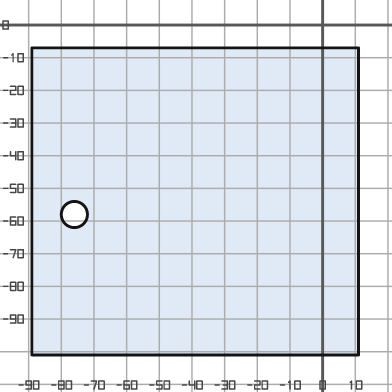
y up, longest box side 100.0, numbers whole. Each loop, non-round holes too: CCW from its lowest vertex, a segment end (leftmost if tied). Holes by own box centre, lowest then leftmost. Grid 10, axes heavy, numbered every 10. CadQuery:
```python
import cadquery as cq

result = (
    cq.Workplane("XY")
    .moveTo(-89.0, -101.0)
    .lineTo(11.0, -101.0)
    .lineTo(11.0, -7.0)
    .lineTo(-89.0, -7.0)
    .close()
    .moveTo(-76.0, -58.0)
    .circle(4.0)
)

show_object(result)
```